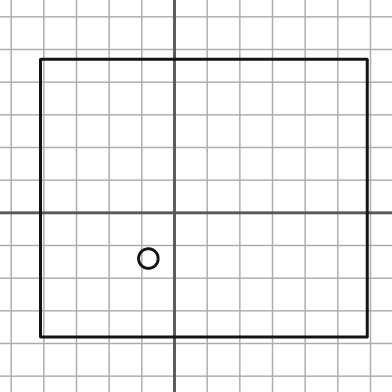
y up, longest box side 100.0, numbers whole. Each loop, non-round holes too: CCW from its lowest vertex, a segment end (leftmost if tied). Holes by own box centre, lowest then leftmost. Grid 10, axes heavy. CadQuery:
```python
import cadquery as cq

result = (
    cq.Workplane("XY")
    .moveTo(-41.0, -38.0)
    .lineTo(59.0, -38.0)
    .lineTo(59.0, 47.0)
    .lineTo(-41.0, 47.0)
    .close()
    .moveTo(-8.0, -14.0)
    .circle(3.0)
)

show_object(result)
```